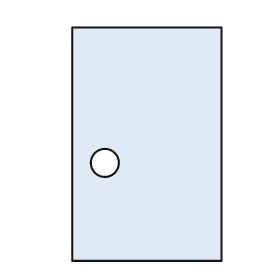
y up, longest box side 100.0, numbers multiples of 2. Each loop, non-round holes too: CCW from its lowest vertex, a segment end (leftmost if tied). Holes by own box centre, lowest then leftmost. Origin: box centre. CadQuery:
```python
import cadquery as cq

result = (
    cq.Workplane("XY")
    .moveTo(-32.0, -50.0)
    .lineTo(32.0, -50.0)
    .lineTo(32.0, 50.0)
    .lineTo(-32.0, 50.0)
    .close()
    .moveTo(-18.0, -8.0)
    .circle(6.0)
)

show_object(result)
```